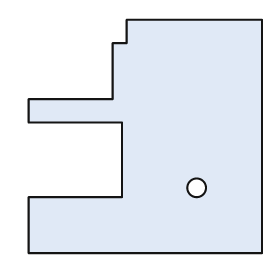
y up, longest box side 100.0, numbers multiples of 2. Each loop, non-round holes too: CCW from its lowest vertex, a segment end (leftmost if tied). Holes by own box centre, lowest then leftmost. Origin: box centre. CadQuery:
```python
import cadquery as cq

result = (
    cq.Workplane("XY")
    .moveTo(-50.0, -50.0)
    .lineTo(50.0, -50.0)
    .lineTo(50.0, 50.0)
    .lineTo(-8.0, 50.0)
    .lineTo(-8.0, 40.0)
    .lineTo(-14.0, 40.0)
    .lineTo(-14.0, 16.0)
    .lineTo(-50.0, 16.0)
    .lineTo(-50.0, 6.0)
    .lineTo(-10.0, 6.0)
    .lineTo(-10.0, -26.0)
    .lineTo(-50.0, -26.0)
    .close()
    .moveTo(22.0, -22.0)
    .circle(4.0)
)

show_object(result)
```